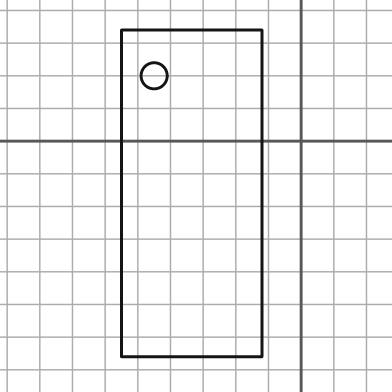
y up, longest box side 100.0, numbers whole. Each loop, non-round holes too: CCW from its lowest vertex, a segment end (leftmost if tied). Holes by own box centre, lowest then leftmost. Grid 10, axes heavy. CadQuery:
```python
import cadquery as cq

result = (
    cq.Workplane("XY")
    .moveTo(-55.0, -66.0)
    .lineTo(-12.0, -66.0)
    .lineTo(-12.0, 34.0)
    .lineTo(-55.0, 34.0)
    .close()
    .moveTo(-45.0, 20.0)
    .circle(4.0)
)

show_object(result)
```